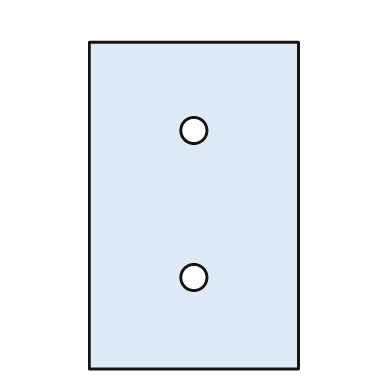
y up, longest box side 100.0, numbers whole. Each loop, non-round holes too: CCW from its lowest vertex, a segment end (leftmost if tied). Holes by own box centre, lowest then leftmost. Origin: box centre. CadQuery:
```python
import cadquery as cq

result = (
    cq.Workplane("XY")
    .moveTo(-32.0, -50.0)
    .lineTo(32.0, -50.0)
    .lineTo(32.0, 50.0)
    .lineTo(-32.0, 50.0)
    .close()
    .moveTo(0.0, -22.0)
    .circle(4.0)
    .moveTo(0.0, 23.0)
    .circle(4.0)
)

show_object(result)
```